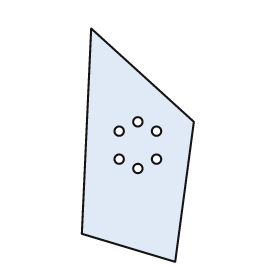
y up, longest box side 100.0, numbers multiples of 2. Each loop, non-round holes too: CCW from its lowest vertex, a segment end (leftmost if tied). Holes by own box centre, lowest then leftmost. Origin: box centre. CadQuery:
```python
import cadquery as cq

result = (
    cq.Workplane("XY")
    .moveTo(16.0, -50.0)
    .lineTo(24.0, 10.0)
    .lineTo(-20.0, 50.0)
    .lineTo(-24.0, -38.0)
    .close()
    .moveTo(0.0, -10.0)
    .circle(2.0)
    .moveTo(-8.0, -6.0)
    .circle(2.0)
    .moveTo(8.0, -6.0)
    .circle(2.0)
    .moveTo(-8.0, 6.0)
    .circle(2.0)
    .moveTo(8.0, 6.0)
    .circle(2.0)
    .moveTo(0.0, 10.0)
    .circle(2.0)
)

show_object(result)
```